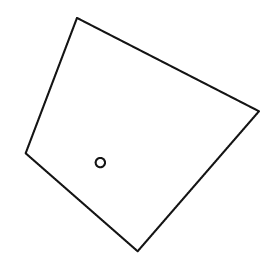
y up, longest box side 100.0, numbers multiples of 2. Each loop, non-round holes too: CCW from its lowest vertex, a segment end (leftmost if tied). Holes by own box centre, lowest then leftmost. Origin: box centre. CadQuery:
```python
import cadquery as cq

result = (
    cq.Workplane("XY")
    .moveTo(-2.0, -50.0)
    .lineTo(50.0, 10.0)
    .lineTo(-28.0, 50.0)
    .lineTo(-50.0, -8.0)
    .close()
    .moveTo(-18.0, -12.0)
    .circle(2.0)
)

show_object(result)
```